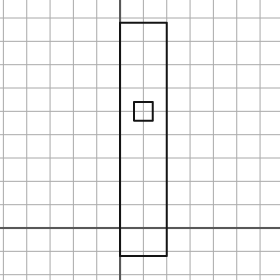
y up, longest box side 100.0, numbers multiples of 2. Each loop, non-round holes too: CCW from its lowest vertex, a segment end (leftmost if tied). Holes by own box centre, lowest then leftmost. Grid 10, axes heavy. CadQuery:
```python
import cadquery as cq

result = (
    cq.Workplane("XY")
    .moveTo(0.0, -12.0)
    .lineTo(20.0, -12.0)
    .lineTo(20.0, 88.0)
    .lineTo(0.0, 88.0)
    .close()
    .moveTo(6.0, 46.0)
    .lineTo(14.0, 46.0)
    .lineTo(14.0, 54.0)
    .lineTo(6.0, 54.0)
    .close()
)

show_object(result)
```